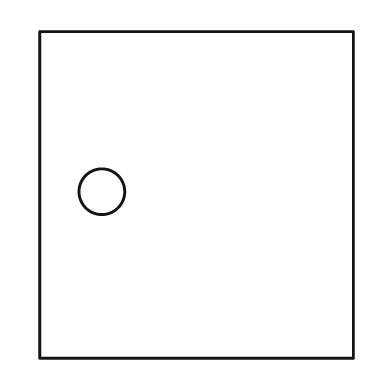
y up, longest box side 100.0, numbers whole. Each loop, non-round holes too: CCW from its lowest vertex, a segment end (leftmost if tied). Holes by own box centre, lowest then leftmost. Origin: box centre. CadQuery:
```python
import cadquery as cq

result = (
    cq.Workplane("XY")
    .moveTo(-48.0, -50.0)
    .lineTo(48.0, -50.0)
    .lineTo(48.0, 50.0)
    .lineTo(-48.0, 50.0)
    .close()
    .moveTo(-29.0, 1.0)
    .circle(7.0)
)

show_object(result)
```